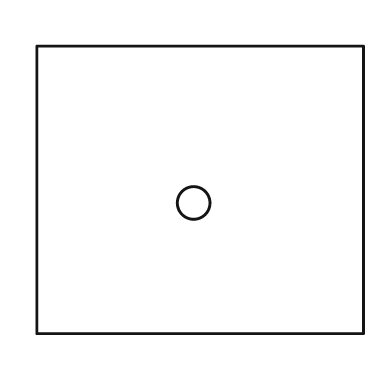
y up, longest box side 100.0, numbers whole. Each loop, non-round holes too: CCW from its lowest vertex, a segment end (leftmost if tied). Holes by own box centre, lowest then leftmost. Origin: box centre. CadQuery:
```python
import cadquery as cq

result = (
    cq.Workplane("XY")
    .moveTo(-50.0, -44.0)
    .lineTo(50.0, -44.0)
    .lineTo(50.0, 44.0)
    .lineTo(-50.0, 44.0)
    .close()
    .moveTo(-2.0, -4.0)
    .circle(5.0)
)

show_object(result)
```